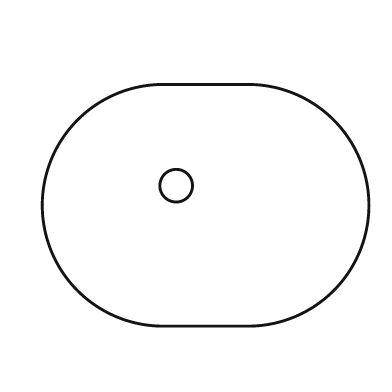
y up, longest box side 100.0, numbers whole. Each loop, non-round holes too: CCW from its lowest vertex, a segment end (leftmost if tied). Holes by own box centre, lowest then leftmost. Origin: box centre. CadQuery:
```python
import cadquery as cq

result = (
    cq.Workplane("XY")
    .moveTo(-13.0, -37.0)
    .lineTo(13.0, -37.0)
    .threePointArc((50.0, 0.0), (13.0, 37.0))
    .lineTo(-13.0, 37.0)
    .threePointArc((-50.0, 0.0), (-13.0, -37.0))
    .close()
    .moveTo(-9.0, 6.0)
    .circle(5.0)
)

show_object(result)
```